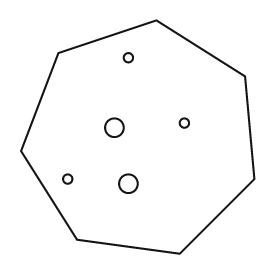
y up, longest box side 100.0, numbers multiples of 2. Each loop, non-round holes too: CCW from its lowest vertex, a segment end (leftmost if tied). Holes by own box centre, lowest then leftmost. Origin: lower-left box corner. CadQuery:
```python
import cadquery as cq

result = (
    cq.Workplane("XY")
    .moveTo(68.0, 0.0)
    .lineTo(100.0, 32.0)
    .lineTo(96.0, 76.0)
    .lineTo(58.0, 100.0)
    .lineTo(16.0, 86.0)
    .lineTo(0.0, 44.0)
    .lineTo(24.0, 6.0)
    .close()
    .moveTo(46.0, 30.0)
    .circle(4.0)
    .moveTo(20.0, 32.0)
    .circle(2.0)
    .moveTo(40.0, 54.0)
    .circle(4.0)
    .moveTo(70.0, 56.0)
    .circle(2.0)
    .moveTo(46.0, 84.0)
    .circle(2.0)
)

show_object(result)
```